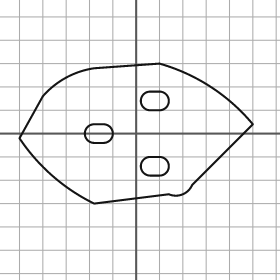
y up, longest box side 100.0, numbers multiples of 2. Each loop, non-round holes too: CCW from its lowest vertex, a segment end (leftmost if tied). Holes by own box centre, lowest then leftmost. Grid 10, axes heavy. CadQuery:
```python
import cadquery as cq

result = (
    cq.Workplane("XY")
    .moveTo(-18.0, -30.0)
    .lineTo(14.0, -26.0)
    .threePointArc((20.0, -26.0), (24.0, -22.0))
    .lineTo(50.0, 4.0)
    .threePointArc((32.0, 20.0), (10.0, 30.0))
    .lineTo(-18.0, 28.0)
    .threePointArc((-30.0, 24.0), (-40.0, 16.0))
    .lineTo(-50.0, -2.0)
    .threePointArc((-36.0, -18.0), (-18.0, -30.0))
    .close()
    .moveTo(6.0, -18.0)
    .lineTo(10.0, -18.0)
    .threePointArc((14.0, -14.0), (10.0, -10.0))
    .lineTo(6.0, -10.0)
    .threePointArc((2.0, -14.0), (6.0, -18.0))
    .close()
    .moveTo(-18.0, -4.0)
    .lineTo(-14.0, -4.0)
    .threePointArc((-10.0, 0.0), (-14.0, 4.0))
    .lineTo(-18.0, 4.0)
    .threePointArc((-22.0, 0.0), (-18.0, -4.0))
    .close()
    .moveTo(6.0, 10.0)
    .lineTo(10.0, 10.0)
    .threePointArc((14.0, 14.0), (10.0, 18.0))
    .lineTo(6.0, 18.0)
    .threePointArc((2.0, 14.0), (6.0, 10.0))
    .close()
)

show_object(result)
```